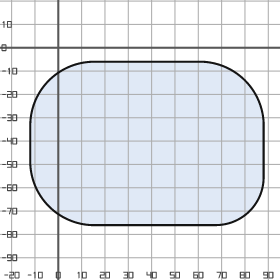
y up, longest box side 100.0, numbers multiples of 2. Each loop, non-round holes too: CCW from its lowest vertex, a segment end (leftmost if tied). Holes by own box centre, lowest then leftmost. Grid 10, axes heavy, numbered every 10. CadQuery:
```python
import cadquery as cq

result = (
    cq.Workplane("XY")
    .moveTo(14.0, -76.0)
    .lineTo(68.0, -76.0)
    .threePointArc((82.0, -70.0), (88.0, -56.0))
    .lineTo(88.0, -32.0)
    .threePointArc((80.0, -14.0), (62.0, -6.0))
    .lineTo(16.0, -6.0)
    .threePointArc((-4.0, -14.0), (-12.0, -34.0))
    .lineTo(-12.0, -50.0)
    .threePointArc((-4.0, -68.0), (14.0, -76.0))
    .close()
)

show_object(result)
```